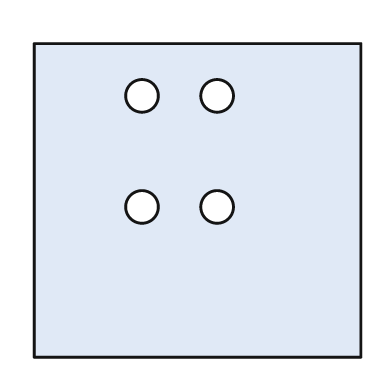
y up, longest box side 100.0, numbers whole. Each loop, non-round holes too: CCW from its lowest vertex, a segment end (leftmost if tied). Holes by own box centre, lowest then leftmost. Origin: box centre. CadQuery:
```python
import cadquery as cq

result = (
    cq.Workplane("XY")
    .moveTo(-50.0, -48.0)
    .lineTo(50.0, -48.0)
    .lineTo(50.0, 48.0)
    .lineTo(-50.0, 48.0)
    .close()
    .moveTo(-17.0, -2.0)
    .circle(5.0)
    .moveTo(6.0, -2.0)
    .circle(5.0)
    .moveTo(-17.0, 32.0)
    .circle(5.0)
    .moveTo(6.0, 32.0)
    .circle(5.0)
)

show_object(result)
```